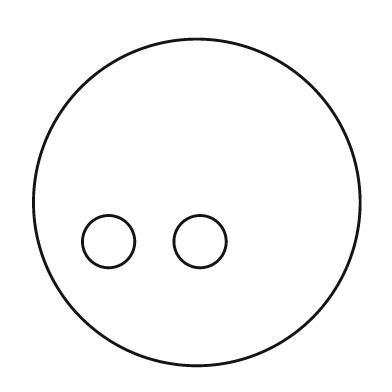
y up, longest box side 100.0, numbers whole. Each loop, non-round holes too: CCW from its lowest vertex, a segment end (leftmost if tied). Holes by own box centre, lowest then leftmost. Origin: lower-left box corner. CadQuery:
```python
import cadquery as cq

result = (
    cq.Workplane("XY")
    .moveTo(50.0, 50.0)
    .circle(50.0)
    .moveTo(23.0, 38.0)
    .circle(8.0)
    .moveTo(51.0, 38.0)
    .circle(8.0)
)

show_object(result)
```